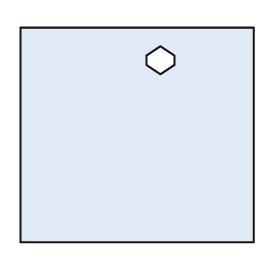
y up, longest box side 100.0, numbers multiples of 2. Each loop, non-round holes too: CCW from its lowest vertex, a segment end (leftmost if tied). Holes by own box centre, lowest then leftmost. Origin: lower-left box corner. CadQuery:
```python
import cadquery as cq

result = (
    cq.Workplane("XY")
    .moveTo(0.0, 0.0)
    .lineTo(100.0, 0.0)
    .lineTo(100.0, 92.0)
    .lineTo(0.0, 92.0)
    .close()
    .moveTo(60.0, 72.0)
    .lineTo(66.0, 76.0)
    .lineTo(66.0, 80.0)
    .lineTo(60.0, 84.0)
    .lineTo(54.0, 80.0)
    .lineTo(54.0, 76.0)
    .close()
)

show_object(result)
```